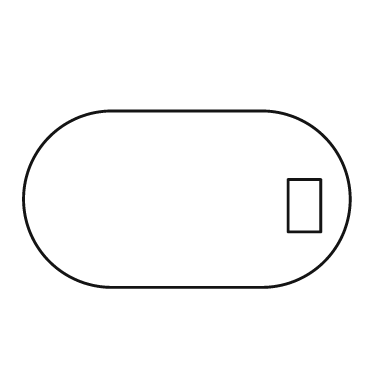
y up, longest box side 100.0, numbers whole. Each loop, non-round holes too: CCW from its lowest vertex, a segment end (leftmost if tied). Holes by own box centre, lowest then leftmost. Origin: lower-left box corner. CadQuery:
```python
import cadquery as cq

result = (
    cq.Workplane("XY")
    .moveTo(27.0, 0.0)
    .lineTo(73.0, 0.0)
    .threePointArc((100.0, 27.0), (73.0, 54.0))
    .lineTo(27.0, 54.0)
    .threePointArc((0.0, 27.0), (27.0, 0.0))
    .close()
    .moveTo(81.0, 17.0)
    .lineTo(91.0, 17.0)
    .lineTo(91.0, 33.0)
    .lineTo(81.0, 33.0)
    .close()
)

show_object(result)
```